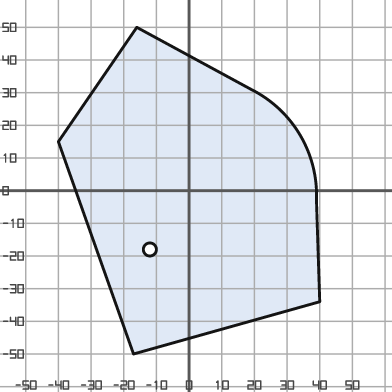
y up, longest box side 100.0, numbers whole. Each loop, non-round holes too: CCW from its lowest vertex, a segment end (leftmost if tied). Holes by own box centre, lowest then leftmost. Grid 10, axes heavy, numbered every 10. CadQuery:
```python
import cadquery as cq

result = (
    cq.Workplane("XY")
    .moveTo(-17.0, -50.0)
    .lineTo(40.0, -34.0)
    .lineTo(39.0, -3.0)
    .threePointArc((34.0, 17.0), (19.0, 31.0))
    .lineTo(-16.0, 50.0)
    .lineTo(-40.0, 15.0)
    .close()
    .moveTo(-12.0, -18.0)
    .circle(2.0)
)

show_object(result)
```